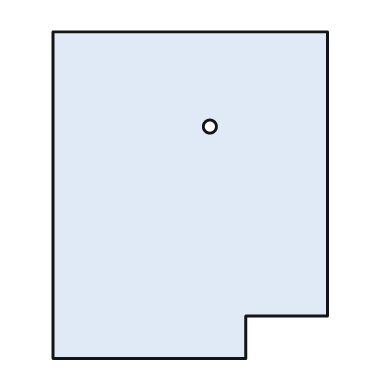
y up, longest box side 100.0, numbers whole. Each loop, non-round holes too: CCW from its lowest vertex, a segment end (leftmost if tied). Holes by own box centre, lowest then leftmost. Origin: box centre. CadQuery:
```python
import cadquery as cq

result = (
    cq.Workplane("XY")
    .moveTo(-42.0, -50.0)
    .lineTo(17.0, -50.0)
    .lineTo(17.0, -37.0)
    .lineTo(42.0, -37.0)
    .lineTo(42.0, 50.0)
    .lineTo(-42.0, 50.0)
    .close()
    .moveTo(6.0, 21.0)
    .circle(2.0)
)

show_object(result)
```